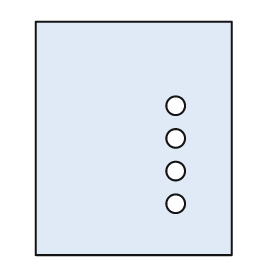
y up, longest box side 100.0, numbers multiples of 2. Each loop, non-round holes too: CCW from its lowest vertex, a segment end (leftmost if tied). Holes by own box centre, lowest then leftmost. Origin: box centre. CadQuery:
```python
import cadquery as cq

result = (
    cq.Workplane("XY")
    .moveTo(-42.0, -50.0)
    .lineTo(42.0, -50.0)
    .lineTo(42.0, 50.0)
    .lineTo(-42.0, 50.0)
    .close()
    .moveTo(18.0, -28.0)
    .circle(4.0)
    .moveTo(18.0, -14.0)
    .circle(4.0)
    .moveTo(18.0, 0.0)
    .circle(4.0)
    .moveTo(18.0, 14.0)
    .circle(4.0)
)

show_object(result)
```